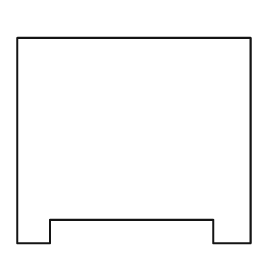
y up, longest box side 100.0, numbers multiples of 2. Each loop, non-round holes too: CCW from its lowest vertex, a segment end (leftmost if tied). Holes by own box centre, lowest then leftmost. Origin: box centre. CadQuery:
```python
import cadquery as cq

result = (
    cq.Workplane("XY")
    .moveTo(-50.0, -44.0)
    .lineTo(-36.0, -44.0)
    .lineTo(-36.0, -34.0)
    .lineTo(34.0, -34.0)
    .lineTo(34.0, -44.0)
    .lineTo(50.0, -44.0)
    .lineTo(50.0, 44.0)
    .lineTo(-50.0, 44.0)
    .close()
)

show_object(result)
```